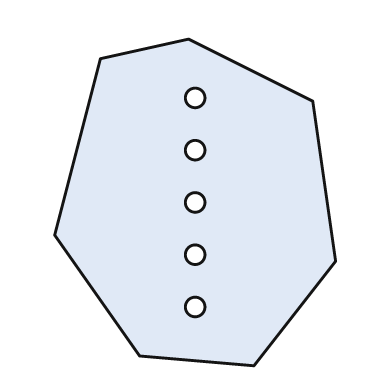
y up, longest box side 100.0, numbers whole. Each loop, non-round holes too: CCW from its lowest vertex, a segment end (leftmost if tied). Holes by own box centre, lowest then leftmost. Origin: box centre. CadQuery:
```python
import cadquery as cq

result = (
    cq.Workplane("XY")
    .moveTo(18.0, -50.0)
    .lineTo(43.0, -18.0)
    .lineTo(36.0, 31.0)
    .lineTo(-2.0, 50.0)
    .lineTo(-29.0, 44.0)
    .lineTo(-43.0, -10.0)
    .lineTo(-17.0, -47.0)
    .close()
    .moveTo(0.0, -32.0)
    .circle(3.0)
    .moveTo(0.0, -16.0)
    .circle(3.0)
    .moveTo(0.0, 0.0)
    .circle(3.0)
    .moveTo(0.0, 16.0)
    .circle(3.0)
    .moveTo(0.0, 32.0)
    .circle(3.0)
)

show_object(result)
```